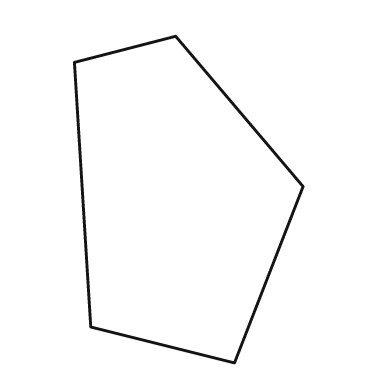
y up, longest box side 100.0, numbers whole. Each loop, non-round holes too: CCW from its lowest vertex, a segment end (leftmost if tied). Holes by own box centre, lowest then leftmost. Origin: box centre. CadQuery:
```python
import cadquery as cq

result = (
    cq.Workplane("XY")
    .moveTo(14.0, -50.0)
    .lineTo(35.0, 4.0)
    .lineTo(-4.0, 50.0)
    .lineTo(-35.0, 42.0)
    .lineTo(-30.0, -39.0)
    .close()
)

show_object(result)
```